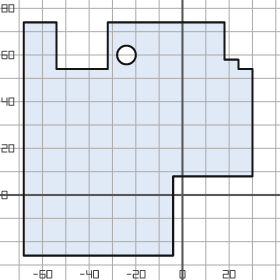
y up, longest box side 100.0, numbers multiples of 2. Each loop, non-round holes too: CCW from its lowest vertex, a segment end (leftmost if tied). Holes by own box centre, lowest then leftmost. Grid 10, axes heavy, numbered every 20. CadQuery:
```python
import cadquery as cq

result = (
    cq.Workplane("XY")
    .moveTo(-68.0, -26.0)
    .lineTo(-4.0, -26.0)
    .lineTo(-4.0, 8.0)
    .lineTo(30.0, 8.0)
    .lineTo(30.0, 54.0)
    .lineTo(24.0, 54.0)
    .lineTo(24.0, 58.0)
    .lineTo(18.0, 58.0)
    .lineTo(18.0, 74.0)
    .lineTo(-32.0, 74.0)
    .lineTo(-32.0, 54.0)
    .lineTo(-54.0, 54.0)
    .lineTo(-54.0, 74.0)
    .lineTo(-68.0, 74.0)
    .close()
    .moveTo(-24.0, 60.0)
    .circle(4.0)
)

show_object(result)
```